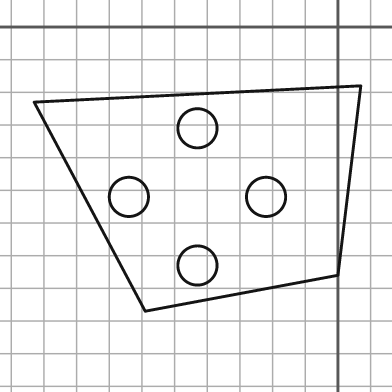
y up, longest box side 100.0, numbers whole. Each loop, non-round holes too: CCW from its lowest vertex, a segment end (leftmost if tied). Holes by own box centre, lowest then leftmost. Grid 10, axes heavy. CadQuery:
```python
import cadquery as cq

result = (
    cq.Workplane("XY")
    .moveTo(-59.0, -87.0)
    .lineTo(0.0, -76.0)
    .lineTo(7.0, -18.0)
    .lineTo(-93.0, -23.0)
    .close()
    .moveTo(-43.0, -73.0)
    .circle(6.0)
    .moveTo(-64.0, -52.0)
    .circle(6.0)
    .moveTo(-22.0, -52.0)
    .circle(6.0)
    .moveTo(-43.0, -31.0)
    .circle(6.0)
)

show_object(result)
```